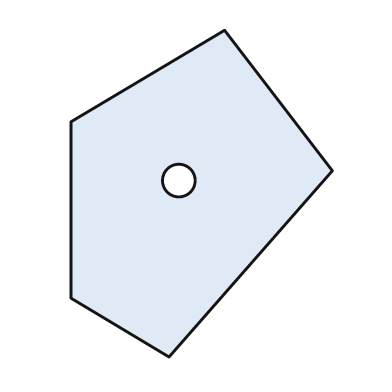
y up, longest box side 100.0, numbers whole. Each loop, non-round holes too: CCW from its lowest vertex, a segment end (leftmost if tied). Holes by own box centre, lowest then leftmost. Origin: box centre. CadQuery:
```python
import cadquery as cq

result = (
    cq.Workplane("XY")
    .moveTo(-10.0, -50.0)
    .lineTo(40.0, 7.0)
    .lineTo(7.0, 50.0)
    .lineTo(-40.0, 22.0)
    .lineTo(-40.0, -32.0)
    .close()
    .moveTo(-7.0, 4.0)
    .circle(5.0)
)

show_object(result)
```